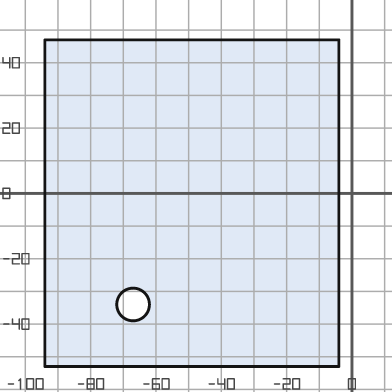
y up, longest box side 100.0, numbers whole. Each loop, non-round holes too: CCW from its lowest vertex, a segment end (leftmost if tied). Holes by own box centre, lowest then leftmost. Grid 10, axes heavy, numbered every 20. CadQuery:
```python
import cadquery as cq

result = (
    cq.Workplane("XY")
    .moveTo(-94.0, -53.0)
    .lineTo(-4.0, -53.0)
    .lineTo(-4.0, 47.0)
    .lineTo(-94.0, 47.0)
    .close()
    .moveTo(-67.0, -34.0)
    .circle(5.0)
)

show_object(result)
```